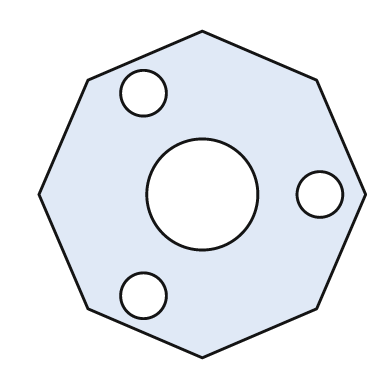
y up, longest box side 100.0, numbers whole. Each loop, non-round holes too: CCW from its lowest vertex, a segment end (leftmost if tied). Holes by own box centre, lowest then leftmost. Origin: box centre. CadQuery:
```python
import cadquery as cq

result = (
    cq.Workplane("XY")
    .moveTo(0.0, -50.0)
    .lineTo(35.0, -35.0)
    .lineTo(50.0, 0.0)
    .lineTo(35.0, 35.0)
    .lineTo(0.0, 50.0)
    .lineTo(-35.0, 35.0)
    .lineTo(-50.0, 0.0)
    .lineTo(-35.0, -35.0)
    .close()
    .moveTo(-18.0, -31.0)
    .circle(7.0)
    .moveTo(0.0, 0.0)
    .circle(17.0)
    .moveTo(36.0, 0.0)
    .circle(7.0)
    .moveTo(-18.0, 31.0)
    .circle(7.0)
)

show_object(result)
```